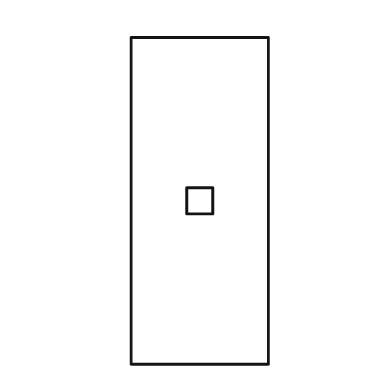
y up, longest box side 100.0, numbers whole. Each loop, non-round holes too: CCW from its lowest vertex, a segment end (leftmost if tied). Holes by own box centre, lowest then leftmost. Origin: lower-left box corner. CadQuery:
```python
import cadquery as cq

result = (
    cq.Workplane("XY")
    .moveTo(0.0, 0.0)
    .lineTo(42.0, 0.0)
    .lineTo(42.0, 100.0)
    .lineTo(0.0, 100.0)
    .close()
    .moveTo(17.0, 46.0)
    .lineTo(25.0, 46.0)
    .lineTo(25.0, 54.0)
    .lineTo(17.0, 54.0)
    .close()
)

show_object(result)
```